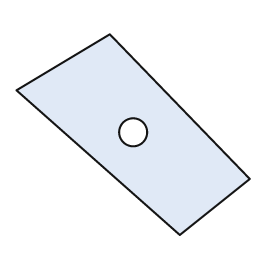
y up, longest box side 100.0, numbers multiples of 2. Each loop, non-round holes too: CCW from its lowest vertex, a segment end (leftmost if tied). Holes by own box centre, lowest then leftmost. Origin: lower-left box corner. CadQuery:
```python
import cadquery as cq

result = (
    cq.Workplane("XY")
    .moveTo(70.0, 0.0)
    .lineTo(100.0, 24.0)
    .lineTo(40.0, 86.0)
    .lineTo(0.0, 62.0)
    .close()
    .moveTo(50.0, 44.0)
    .circle(6.0)
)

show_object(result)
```